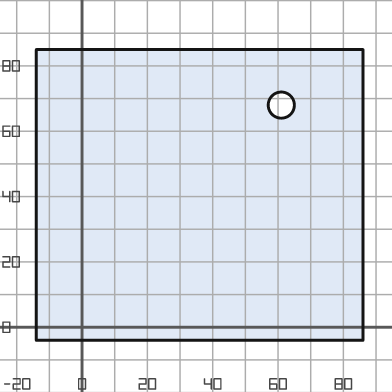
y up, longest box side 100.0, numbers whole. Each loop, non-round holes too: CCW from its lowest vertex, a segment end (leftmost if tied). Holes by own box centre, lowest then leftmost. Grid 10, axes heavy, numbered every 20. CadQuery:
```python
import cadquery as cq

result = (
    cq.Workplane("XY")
    .moveTo(-14.0, -4.0)
    .lineTo(86.0, -4.0)
    .lineTo(86.0, 85.0)
    .lineTo(-14.0, 85.0)
    .close()
    .moveTo(61.0, 68.0)
    .circle(4.0)
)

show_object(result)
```